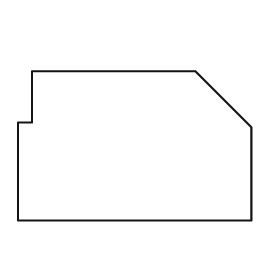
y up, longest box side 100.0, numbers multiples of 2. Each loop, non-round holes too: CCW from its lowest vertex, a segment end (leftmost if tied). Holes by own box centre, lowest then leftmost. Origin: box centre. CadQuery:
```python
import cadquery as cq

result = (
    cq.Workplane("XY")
    .moveTo(-50.0, -32.0)
    .lineTo(50.0, -32.0)
    .lineTo(50.0, 8.0)
    .lineTo(26.0, 32.0)
    .lineTo(-44.0, 32.0)
    .lineTo(-44.0, 10.0)
    .lineTo(-50.0, 10.0)
    .close()
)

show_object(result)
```